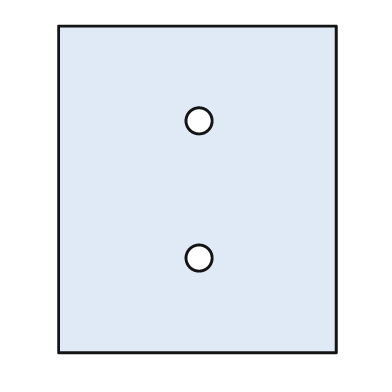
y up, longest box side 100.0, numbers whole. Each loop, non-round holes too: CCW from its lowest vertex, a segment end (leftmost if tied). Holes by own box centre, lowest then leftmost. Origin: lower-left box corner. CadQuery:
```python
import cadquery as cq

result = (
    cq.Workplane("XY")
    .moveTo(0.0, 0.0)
    .lineTo(85.0, 0.0)
    .lineTo(85.0, 100.0)
    .lineTo(0.0, 100.0)
    .close()
    .moveTo(43.0, 29.0)
    .circle(4.0)
    .moveTo(43.0, 71.0)
    .circle(4.0)
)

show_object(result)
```